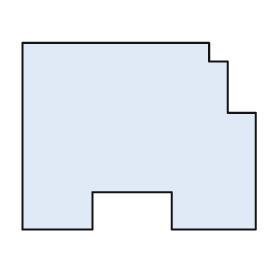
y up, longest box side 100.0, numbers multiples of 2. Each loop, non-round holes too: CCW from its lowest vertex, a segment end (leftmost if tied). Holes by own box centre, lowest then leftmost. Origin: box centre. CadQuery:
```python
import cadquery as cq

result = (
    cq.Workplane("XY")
    .moveTo(-50.0, -40.0)
    .lineTo(-20.0, -40.0)
    .lineTo(-20.0, -24.0)
    .lineTo(14.0, -24.0)
    .lineTo(14.0, -40.0)
    .lineTo(50.0, -40.0)
    .lineTo(50.0, 10.0)
    .lineTo(38.0, 10.0)
    .lineTo(38.0, 32.0)
    .lineTo(30.0, 32.0)
    .lineTo(30.0, 40.0)
    .lineTo(-50.0, 40.0)
    .close()
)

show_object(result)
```